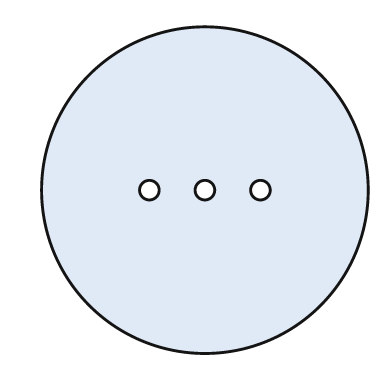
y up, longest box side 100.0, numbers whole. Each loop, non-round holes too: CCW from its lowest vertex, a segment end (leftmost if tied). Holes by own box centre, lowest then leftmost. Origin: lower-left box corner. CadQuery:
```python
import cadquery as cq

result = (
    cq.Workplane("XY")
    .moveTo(50.0, 50.0)
    .circle(50.0)
    .moveTo(33.0, 50.0)
    .circle(3.0)
    .moveTo(50.0, 50.0)
    .circle(3.0)
    .moveTo(67.0, 50.0)
    .circle(3.0)
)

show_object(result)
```